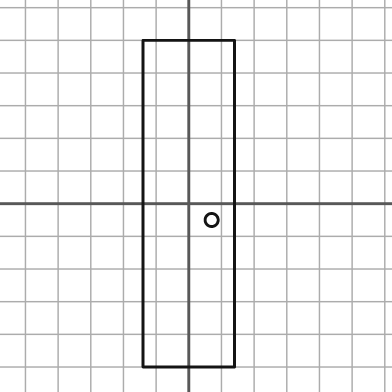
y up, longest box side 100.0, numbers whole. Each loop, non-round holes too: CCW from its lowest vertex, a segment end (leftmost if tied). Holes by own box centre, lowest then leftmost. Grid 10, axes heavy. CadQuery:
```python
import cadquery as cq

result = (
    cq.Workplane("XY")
    .moveTo(-14.0, -50.0)
    .lineTo(14.0, -50.0)
    .lineTo(14.0, 50.0)
    .lineTo(-14.0, 50.0)
    .close()
    .moveTo(7.0, -5.0)
    .circle(2.0)
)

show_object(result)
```